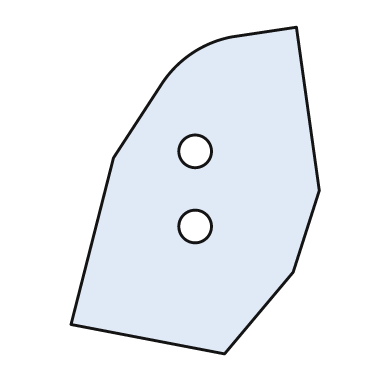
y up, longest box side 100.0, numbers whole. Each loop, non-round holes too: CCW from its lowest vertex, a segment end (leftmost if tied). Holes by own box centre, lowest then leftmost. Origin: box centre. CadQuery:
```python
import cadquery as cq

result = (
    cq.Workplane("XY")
    .moveTo(9.0, -50.0)
    .lineTo(30.0, -25.0)
    .lineTo(38.0, 0.0)
    .lineTo(31.0, 50.0)
    .lineTo(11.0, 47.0)
    .threePointArc((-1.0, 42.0), (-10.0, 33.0))
    .lineTo(-25.0, 10.0)
    .lineTo(-38.0, -41.0)
    .close()
    .moveTo(0.0, -11.0)
    .circle(5.0)
    .moveTo(0.0, 12.0)
    .circle(5.0)
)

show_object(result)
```